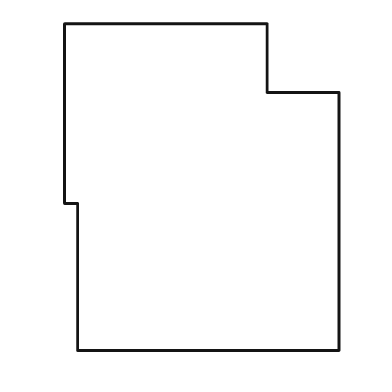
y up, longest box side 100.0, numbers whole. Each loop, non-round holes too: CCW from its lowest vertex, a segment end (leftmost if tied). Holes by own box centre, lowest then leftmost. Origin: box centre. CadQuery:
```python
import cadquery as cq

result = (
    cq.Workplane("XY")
    .moveTo(-38.0, -50.0)
    .lineTo(42.0, -50.0)
    .lineTo(42.0, 29.0)
    .lineTo(20.0, 29.0)
    .lineTo(20.0, 50.0)
    .lineTo(-42.0, 50.0)
    .lineTo(-42.0, -5.0)
    .lineTo(-38.0, -5.0)
    .close()
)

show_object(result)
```